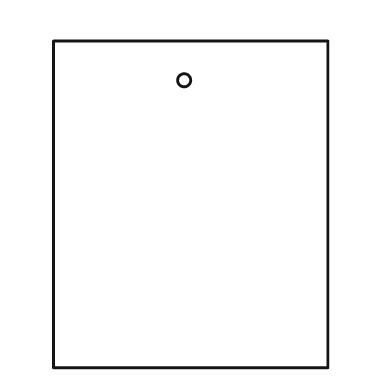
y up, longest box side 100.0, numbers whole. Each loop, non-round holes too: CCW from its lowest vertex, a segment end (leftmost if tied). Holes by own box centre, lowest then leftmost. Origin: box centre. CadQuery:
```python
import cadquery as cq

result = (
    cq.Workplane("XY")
    .moveTo(-42.0, -50.0)
    .lineTo(42.0, -50.0)
    .lineTo(42.0, 50.0)
    .lineTo(-42.0, 50.0)
    .close()
    .moveTo(-2.0, 38.0)
    .circle(2.0)
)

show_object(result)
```